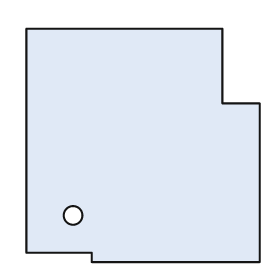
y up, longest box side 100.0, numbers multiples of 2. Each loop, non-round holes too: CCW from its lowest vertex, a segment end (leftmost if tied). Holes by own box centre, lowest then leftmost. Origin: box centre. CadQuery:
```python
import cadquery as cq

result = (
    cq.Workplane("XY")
    .moveTo(-22.0, -50.0)
    .lineTo(50.0, -50.0)
    .lineTo(50.0, 18.0)
    .lineTo(34.0, 18.0)
    .lineTo(34.0, 50.0)
    .lineTo(-50.0, 50.0)
    .lineTo(-50.0, -46.0)
    .lineTo(-22.0, -46.0)
    .close()
    .moveTo(-30.0, -30.0)
    .circle(4.0)
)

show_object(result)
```